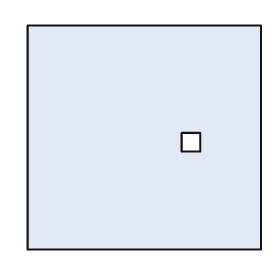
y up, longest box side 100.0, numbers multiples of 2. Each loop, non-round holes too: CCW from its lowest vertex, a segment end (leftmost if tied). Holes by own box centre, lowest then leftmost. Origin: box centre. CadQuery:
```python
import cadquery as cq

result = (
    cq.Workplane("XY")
    .moveTo(-50.0, -48.0)
    .lineTo(50.0, -48.0)
    .lineTo(50.0, 48.0)
    .lineTo(-50.0, 48.0)
    .close()
    .moveTo(16.0, -6.0)
    .lineTo(24.0, -6.0)
    .lineTo(24.0, 2.0)
    .lineTo(16.0, 2.0)
    .close()
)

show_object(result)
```